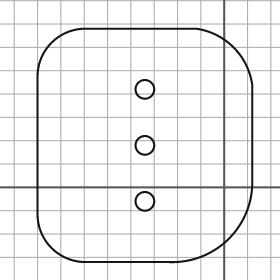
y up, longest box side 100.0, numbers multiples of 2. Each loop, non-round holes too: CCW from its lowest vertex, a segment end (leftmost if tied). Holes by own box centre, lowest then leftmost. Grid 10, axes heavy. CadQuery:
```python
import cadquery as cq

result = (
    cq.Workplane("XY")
    .moveTo(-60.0, -32.0)
    .lineTo(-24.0, -32.0)
    .threePointArc((2.0, -22.0), (12.0, 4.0))
    .lineTo(12.0, 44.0)
    .threePointArc((4.0, 60.0), (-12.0, 68.0))
    .lineTo(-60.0, 68.0)
    .threePointArc((-74.0, 62.0), (-80.0, 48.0))
    .lineTo(-80.0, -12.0)
    .threePointArc((-74.0, -26.0), (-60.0, -32.0))
    .close()
    .moveTo(-34.0, -6.0)
    .circle(4.0)
    .moveTo(-34.0, 18.0)
    .circle(4.0)
    .moveTo(-34.0, 42.0)
    .circle(4.0)
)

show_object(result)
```